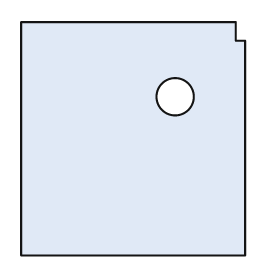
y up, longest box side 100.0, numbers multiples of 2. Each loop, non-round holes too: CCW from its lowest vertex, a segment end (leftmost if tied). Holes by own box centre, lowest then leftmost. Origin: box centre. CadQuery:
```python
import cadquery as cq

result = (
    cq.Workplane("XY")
    .moveTo(-48.0, -50.0)
    .lineTo(48.0, -50.0)
    .lineTo(48.0, 42.0)
    .lineTo(44.0, 42.0)
    .lineTo(44.0, 50.0)
    .lineTo(-48.0, 50.0)
    .close()
    .moveTo(18.0, 18.0)
    .circle(8.0)
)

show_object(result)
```